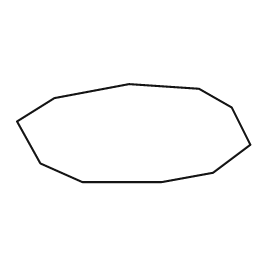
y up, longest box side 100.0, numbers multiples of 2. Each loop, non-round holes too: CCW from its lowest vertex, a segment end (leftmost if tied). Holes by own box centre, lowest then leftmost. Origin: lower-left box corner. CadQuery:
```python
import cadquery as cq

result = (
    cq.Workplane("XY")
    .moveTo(28.0, 0.0)
    .lineTo(62.0, 0.0)
    .lineTo(84.0, 4.0)
    .lineTo(100.0, 16.0)
    .lineTo(92.0, 32.0)
    .lineTo(78.0, 40.0)
    .lineTo(48.0, 42.0)
    .lineTo(16.0, 36.0)
    .lineTo(0.0, 26.0)
    .lineTo(10.0, 8.0)
    .close()
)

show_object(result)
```